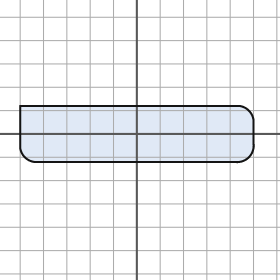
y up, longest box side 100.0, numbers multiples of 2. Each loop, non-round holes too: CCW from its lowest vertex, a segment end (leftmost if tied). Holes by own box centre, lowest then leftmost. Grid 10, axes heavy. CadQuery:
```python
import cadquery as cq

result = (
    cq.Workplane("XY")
    .moveTo(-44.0, -12.0)
    .lineTo(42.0, -12.0)
    .threePointArc((48.0, -10.0), (50.0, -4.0))
    .lineTo(50.0, 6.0)
    .threePointArc((48.0, 10.0), (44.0, 12.0))
    .lineTo(-50.0, 12.0)
    .lineTo(-50.0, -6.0)
    .threePointArc((-48.0, -10.0), (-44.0, -12.0))
    .close()
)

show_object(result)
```